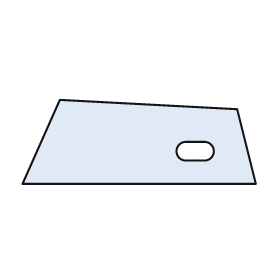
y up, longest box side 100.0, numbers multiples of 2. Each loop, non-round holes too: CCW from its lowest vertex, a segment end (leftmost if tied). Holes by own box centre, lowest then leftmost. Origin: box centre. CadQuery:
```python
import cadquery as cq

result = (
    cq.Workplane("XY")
    .moveTo(-50.0, -18.0)
    .lineTo(50.0, -18.0)
    .lineTo(42.0, 14.0)
    .lineTo(-34.0, 18.0)
    .close()
    .moveTo(20.0, -8.0)
    .lineTo(28.0, -8.0)
    .threePointArc((32.0, -4.0), (28.0, 0.0))
    .lineTo(20.0, 0.0)
    .threePointArc((16.0, -4.0), (20.0, -8.0))
    .close()
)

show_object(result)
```